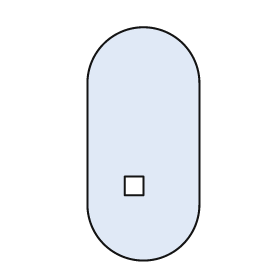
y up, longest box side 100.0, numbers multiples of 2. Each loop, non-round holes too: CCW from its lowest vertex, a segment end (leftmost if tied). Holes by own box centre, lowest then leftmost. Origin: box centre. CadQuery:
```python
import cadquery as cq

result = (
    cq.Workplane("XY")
    .moveTo(-24.0, -26.0)
    .threePointArc((0.0, -50.0), (24.0, -26.0))
    .lineTo(24.0, 26.0)
    .threePointArc((0.0, 50.0), (-24.0, 26.0))
    .close()
    .moveTo(-8.0, -22.0)
    .lineTo(0.0, -22.0)
    .lineTo(0.0, -14.0)
    .lineTo(-8.0, -14.0)
    .close()
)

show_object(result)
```